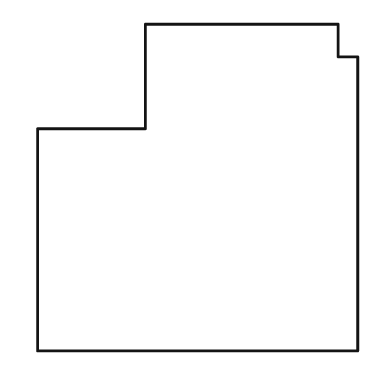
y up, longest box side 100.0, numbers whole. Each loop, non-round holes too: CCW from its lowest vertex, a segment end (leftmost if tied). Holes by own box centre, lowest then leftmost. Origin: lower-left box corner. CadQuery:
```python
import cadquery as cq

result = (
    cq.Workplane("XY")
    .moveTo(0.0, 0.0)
    .lineTo(98.0, 0.0)
    .lineTo(98.0, 90.0)
    .lineTo(92.0, 90.0)
    .lineTo(92.0, 100.0)
    .lineTo(33.0, 100.0)
    .lineTo(33.0, 68.0)
    .lineTo(0.0, 68.0)
    .close()
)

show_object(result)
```